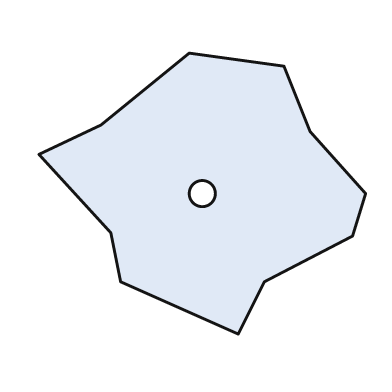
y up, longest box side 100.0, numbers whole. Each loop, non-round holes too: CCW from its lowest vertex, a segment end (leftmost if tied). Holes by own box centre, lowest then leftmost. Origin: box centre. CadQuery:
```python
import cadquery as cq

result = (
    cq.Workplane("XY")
    .moveTo(11.0, -43.0)
    .lineTo(19.0, -27.0)
    .lineTo(46.0, -13.0)
    .lineTo(50.0, 0.0)
    .lineTo(33.0, 19.0)
    .lineTo(25.0, 39.0)
    .lineTo(-4.0, 43.0)
    .lineTo(-31.0, 21.0)
    .lineTo(-50.0, 12.0)
    .lineTo(-28.0, -12.0)
    .lineTo(-25.0, -27.0)
    .close()
    .moveTo(0.0, 0.0)
    .circle(4.0)
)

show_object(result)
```